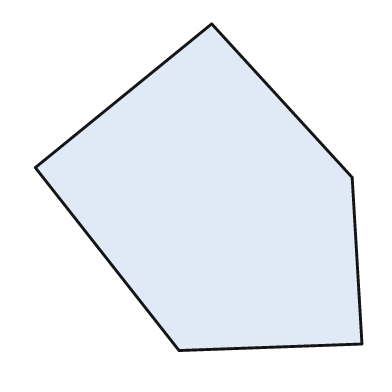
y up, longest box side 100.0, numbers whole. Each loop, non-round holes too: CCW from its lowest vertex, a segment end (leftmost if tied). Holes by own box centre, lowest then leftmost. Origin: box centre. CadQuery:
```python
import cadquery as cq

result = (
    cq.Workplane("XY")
    .moveTo(-6.0, -50.0)
    .lineTo(50.0, -48.0)
    .lineTo(47.0, 3.0)
    .lineTo(4.0, 50.0)
    .lineTo(-50.0, 6.0)
    .close()
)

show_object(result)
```